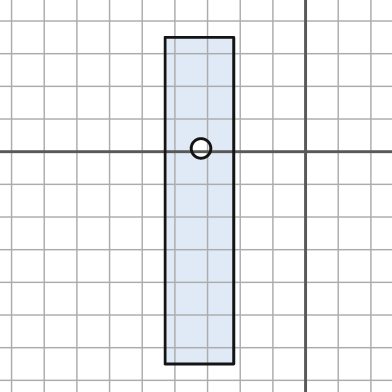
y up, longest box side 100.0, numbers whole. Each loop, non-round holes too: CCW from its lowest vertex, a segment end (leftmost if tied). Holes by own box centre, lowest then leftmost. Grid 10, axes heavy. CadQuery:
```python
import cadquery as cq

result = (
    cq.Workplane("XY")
    .moveTo(-43.0, -65.0)
    .lineTo(-22.0, -65.0)
    .lineTo(-22.0, 35.0)
    .lineTo(-43.0, 35.0)
    .close()
    .moveTo(-32.0, 1.0)
    .circle(3.0)
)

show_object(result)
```